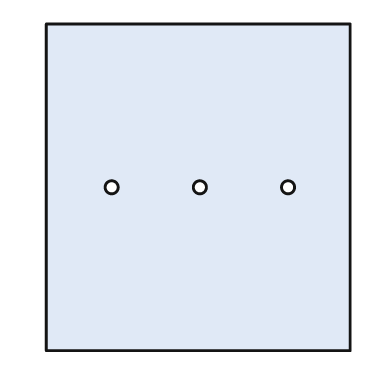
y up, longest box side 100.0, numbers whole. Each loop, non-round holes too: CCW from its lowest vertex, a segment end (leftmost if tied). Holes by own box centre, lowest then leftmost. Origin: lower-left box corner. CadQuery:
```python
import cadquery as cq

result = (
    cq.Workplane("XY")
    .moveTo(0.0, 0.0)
    .lineTo(93.0, 0.0)
    .lineTo(93.0, 100.0)
    .lineTo(0.0, 100.0)
    .close()
    .moveTo(20.0, 50.0)
    .circle(2.0)
    .moveTo(47.0, 50.0)
    .circle(2.0)
    .moveTo(74.0, 50.0)
    .circle(2.0)
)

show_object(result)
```